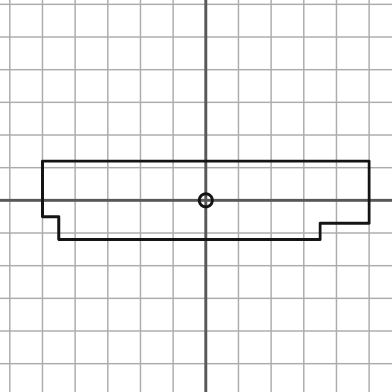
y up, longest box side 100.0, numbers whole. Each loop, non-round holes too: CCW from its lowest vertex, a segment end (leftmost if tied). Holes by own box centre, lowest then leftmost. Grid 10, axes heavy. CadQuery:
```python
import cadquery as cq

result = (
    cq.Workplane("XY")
    .moveTo(-45.0, -12.0)
    .lineTo(35.0, -12.0)
    .lineTo(35.0, -7.0)
    .lineTo(50.0, -7.0)
    .lineTo(50.0, 12.0)
    .lineTo(-50.0, 12.0)
    .lineTo(-50.0, -5.0)
    .lineTo(-45.0, -5.0)
    .close()
    .moveTo(0.0, 0.0)
    .circle(2.0)
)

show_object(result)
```